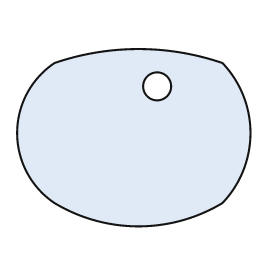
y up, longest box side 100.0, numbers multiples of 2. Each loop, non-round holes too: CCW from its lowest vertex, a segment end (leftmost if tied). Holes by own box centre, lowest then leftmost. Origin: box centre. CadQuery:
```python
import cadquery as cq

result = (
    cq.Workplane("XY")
    .moveTo(-34.0, -28.0)
    .threePointArc((2.0, -38.0), (38.0, -28.0))
    .threePointArc((50.0, 2.0), (38.0, 32.0))
    .threePointArc((2.0, 38.0), (-34.0, 32.0))
    .threePointArc((-50.0, 2.0), (-34.0, -28.0))
    .close()
    .moveTo(10.0, 22.0)
    .circle(6.0)
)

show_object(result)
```